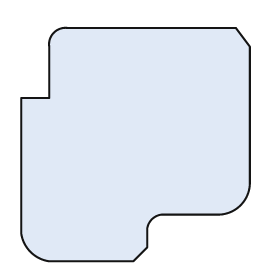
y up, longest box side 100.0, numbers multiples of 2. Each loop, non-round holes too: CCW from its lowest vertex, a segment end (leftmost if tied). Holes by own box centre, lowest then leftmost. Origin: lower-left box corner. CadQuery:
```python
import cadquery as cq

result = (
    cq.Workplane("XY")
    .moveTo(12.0, 0.0)
    .lineTo(48.0, 0.0)
    .lineTo(54.0, 6.0)
    .lineTo(54.0, 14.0)
    .threePointArc((56.0, 18.0), (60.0, 20.0))
    .lineTo(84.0, 20.0)
    .threePointArc((94.0, 24.0), (98.0, 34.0))
    .lineTo(98.0, 92.0)
    .lineTo(92.0, 100.0)
    .lineTo(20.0, 100.0)
    .threePointArc((14.0, 98.0), (12.0, 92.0))
    .lineTo(12.0, 70.0)
    .lineTo(0.0, 70.0)
    .lineTo(0.0, 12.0)
    .threePointArc((4.0, 4.0), (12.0, 0.0))
    .close()
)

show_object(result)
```